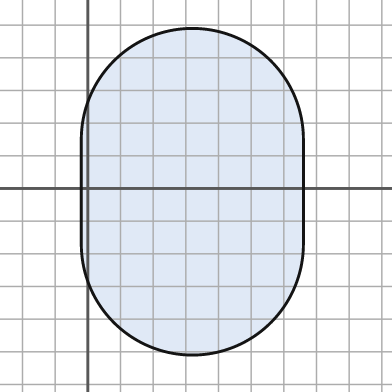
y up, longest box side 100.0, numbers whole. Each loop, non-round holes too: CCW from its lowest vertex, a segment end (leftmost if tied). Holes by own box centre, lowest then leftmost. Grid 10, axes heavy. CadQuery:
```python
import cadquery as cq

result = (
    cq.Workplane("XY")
    .moveTo(-2.0, -17.0)
    .threePointArc((32.0, -51.0), (66.0, -17.0))
    .lineTo(66.0, 15.0)
    .threePointArc((32.0, 49.0), (-2.0, 15.0))
    .close()
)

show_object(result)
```